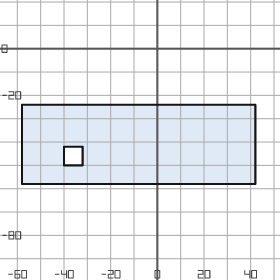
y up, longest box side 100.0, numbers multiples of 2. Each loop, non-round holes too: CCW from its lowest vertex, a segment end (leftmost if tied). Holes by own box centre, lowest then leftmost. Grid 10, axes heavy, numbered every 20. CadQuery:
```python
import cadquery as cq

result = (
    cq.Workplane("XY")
    .moveTo(-58.0, -58.0)
    .lineTo(42.0, -58.0)
    .lineTo(42.0, -24.0)
    .lineTo(-58.0, -24.0)
    .close()
    .moveTo(-40.0, -50.0)
    .lineTo(-32.0, -50.0)
    .lineTo(-32.0, -42.0)
    .lineTo(-40.0, -42.0)
    .close()
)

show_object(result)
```